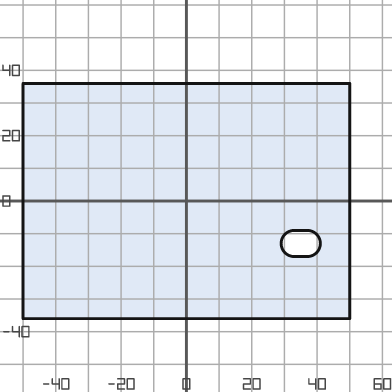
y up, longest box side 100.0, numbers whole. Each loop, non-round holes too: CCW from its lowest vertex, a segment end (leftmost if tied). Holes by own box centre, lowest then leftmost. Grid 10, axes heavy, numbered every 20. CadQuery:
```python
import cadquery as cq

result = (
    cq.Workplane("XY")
    .moveTo(-50.0, -36.0)
    .lineTo(50.0, -36.0)
    .lineTo(50.0, 36.0)
    .lineTo(-50.0, 36.0)
    .close()
    .moveTo(33.0, -17.0)
    .lineTo(37.0, -17.0)
    .threePointArc((41.0, -13.0), (37.0, -9.0))
    .lineTo(33.0, -9.0)
    .threePointArc((29.0, -13.0), (33.0, -17.0))
    .close()
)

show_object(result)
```